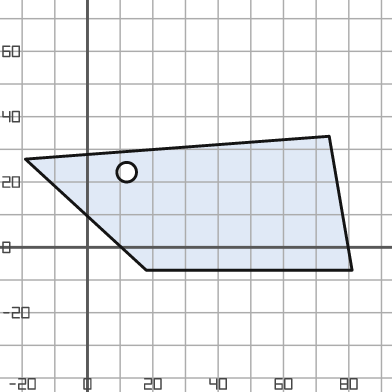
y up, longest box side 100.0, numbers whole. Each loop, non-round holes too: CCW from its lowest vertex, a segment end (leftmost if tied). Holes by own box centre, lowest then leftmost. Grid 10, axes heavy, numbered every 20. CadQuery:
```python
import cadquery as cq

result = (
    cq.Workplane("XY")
    .moveTo(18.0, -7.0)
    .lineTo(81.0, -7.0)
    .lineTo(74.0, 34.0)
    .lineTo(-19.0, 27.0)
    .close()
    .moveTo(12.0, 23.0)
    .circle(3.0)
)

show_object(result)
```